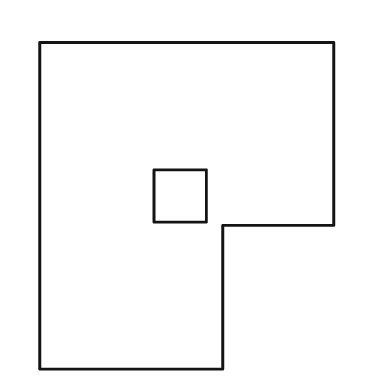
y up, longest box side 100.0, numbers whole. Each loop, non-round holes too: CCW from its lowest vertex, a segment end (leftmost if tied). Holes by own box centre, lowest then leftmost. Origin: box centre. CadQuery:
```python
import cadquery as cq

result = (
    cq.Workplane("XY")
    .moveTo(-45.0, -50.0)
    .lineTo(11.0, -50.0)
    .lineTo(11.0, -6.0)
    .lineTo(45.0, -6.0)
    .lineTo(45.0, 50.0)
    .lineTo(-45.0, 50.0)
    .close()
    .moveTo(-10.0, -5.0)
    .lineTo(6.0, -5.0)
    .lineTo(6.0, 11.0)
    .lineTo(-10.0, 11.0)
    .close()
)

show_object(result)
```